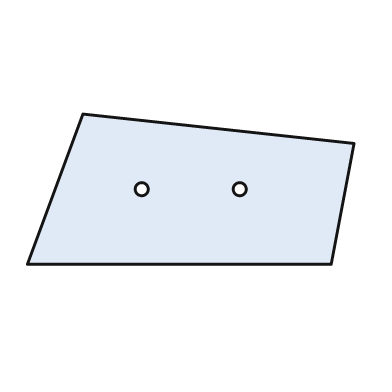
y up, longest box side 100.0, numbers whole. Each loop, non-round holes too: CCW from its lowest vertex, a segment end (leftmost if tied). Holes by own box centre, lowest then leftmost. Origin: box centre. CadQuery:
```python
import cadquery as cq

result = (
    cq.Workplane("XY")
    .moveTo(-50.0, -23.0)
    .lineTo(43.0, -23.0)
    .lineTo(50.0, 14.0)
    .lineTo(-33.0, 23.0)
    .close()
    .moveTo(-15.0, 0.0)
    .circle(2.0)
    .moveTo(15.0, 0.0)
    .circle(2.0)
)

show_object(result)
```